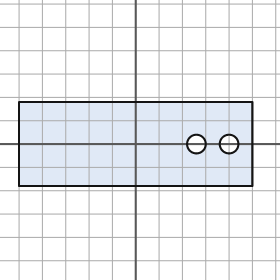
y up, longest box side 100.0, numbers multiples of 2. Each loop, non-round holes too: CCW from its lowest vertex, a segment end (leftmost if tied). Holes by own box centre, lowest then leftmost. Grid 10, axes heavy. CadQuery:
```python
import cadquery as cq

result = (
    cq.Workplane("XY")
    .moveTo(-50.0, -18.0)
    .lineTo(50.0, -18.0)
    .lineTo(50.0, 18.0)
    .lineTo(-50.0, 18.0)
    .close()
    .moveTo(26.0, 0.0)
    .circle(4.0)
    .moveTo(40.0, 0.0)
    .circle(4.0)
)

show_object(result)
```